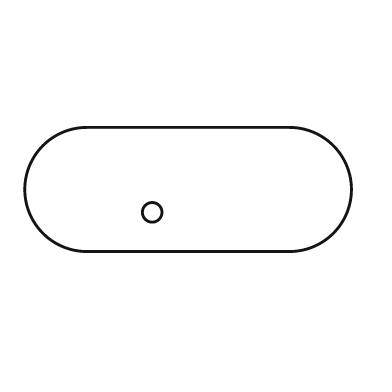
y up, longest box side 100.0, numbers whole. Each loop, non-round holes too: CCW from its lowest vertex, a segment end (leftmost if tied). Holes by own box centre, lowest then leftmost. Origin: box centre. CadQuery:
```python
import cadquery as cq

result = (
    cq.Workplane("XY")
    .moveTo(-31.0, -19.0)
    .lineTo(31.0, -19.0)
    .threePointArc((50.0, 0.0), (31.0, 19.0))
    .lineTo(-31.0, 19.0)
    .threePointArc((-50.0, 0.0), (-31.0, -19.0))
    .close()
    .moveTo(-11.0, -7.0)
    .circle(3.0)
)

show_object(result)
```